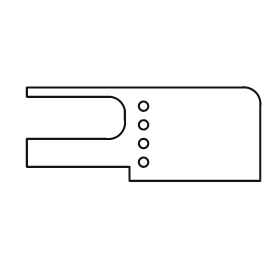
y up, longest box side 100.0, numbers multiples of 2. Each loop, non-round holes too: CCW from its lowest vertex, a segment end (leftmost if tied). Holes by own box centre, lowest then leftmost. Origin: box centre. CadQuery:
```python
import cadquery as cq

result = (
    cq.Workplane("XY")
    .moveTo(-6.0, -20.0)
    .lineTo(50.0, -20.0)
    .lineTo(50.0, 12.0)
    .threePointArc((48.0, 18.0), (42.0, 20.0))
    .lineTo(-50.0, 20.0)
    .lineTo(-50.0, 16.0)
    .lineTo(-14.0, 16.0)
    .threePointArc((-10.0, 14.0), (-8.0, 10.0))
    .lineTo(-8.0, 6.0)
    .threePointArc((-10.0, 0.0), (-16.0, -2.0))
    .lineTo(-50.0, -2.0)
    .lineTo(-50.0, -14.0)
    .lineTo(-6.0, -14.0)
    .close()
    .moveTo(0.0, -12.0)
    .circle(2.0)
    .moveTo(0.0, -4.0)
    .circle(2.0)
    .moveTo(0.0, 4.0)
    .circle(2.0)
    .moveTo(0.0, 12.0)
    .circle(2.0)
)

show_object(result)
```